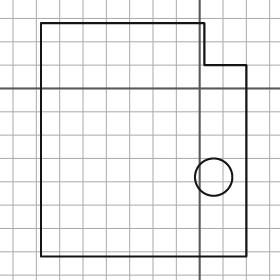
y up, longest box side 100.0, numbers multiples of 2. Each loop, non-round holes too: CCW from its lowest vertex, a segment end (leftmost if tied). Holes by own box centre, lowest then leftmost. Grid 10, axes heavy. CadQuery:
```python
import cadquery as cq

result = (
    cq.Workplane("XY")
    .moveTo(-68.0, -72.0)
    .lineTo(20.0, -72.0)
    .lineTo(20.0, 10.0)
    .lineTo(2.0, 10.0)
    .lineTo(2.0, 28.0)
    .lineTo(-68.0, 28.0)
    .close()
    .moveTo(6.0, -38.0)
    .circle(8.0)
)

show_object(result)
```